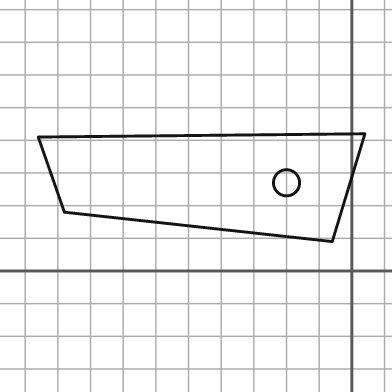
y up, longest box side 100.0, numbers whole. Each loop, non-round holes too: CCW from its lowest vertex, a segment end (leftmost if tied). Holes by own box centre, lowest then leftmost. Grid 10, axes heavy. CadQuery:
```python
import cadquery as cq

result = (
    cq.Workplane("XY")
    .moveTo(-6.0, 9.0)
    .lineTo(4.0, 42.0)
    .lineTo(-96.0, 41.0)
    .lineTo(-88.0, 18.0)
    .close()
    .moveTo(-20.0, 27.0)
    .circle(4.0)
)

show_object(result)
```